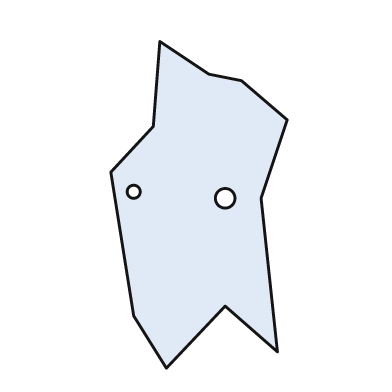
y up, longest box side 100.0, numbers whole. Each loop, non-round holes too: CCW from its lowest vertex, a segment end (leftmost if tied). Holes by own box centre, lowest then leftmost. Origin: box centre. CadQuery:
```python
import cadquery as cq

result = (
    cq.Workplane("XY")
    .moveTo(-10.0, -50.0)
    .lineTo(8.0, -31.0)
    .lineTo(24.0, -45.0)
    .lineTo(19.0, 2.0)
    .lineTo(27.0, 26.0)
    .lineTo(13.0, 38.0)
    .lineTo(3.0, 40.0)
    .lineTo(-12.0, 50.0)
    .lineTo(-14.0, 24.0)
    .lineTo(-27.0, 10.0)
    .lineTo(-20.0, -34.0)
    .close()
    .moveTo(8.0, 2.0)
    .circle(3.0)
    .moveTo(-20.0, 4.0)
    .circle(2.0)
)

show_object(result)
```